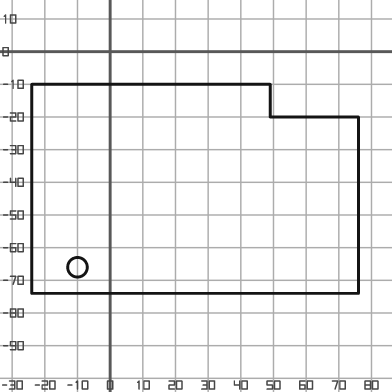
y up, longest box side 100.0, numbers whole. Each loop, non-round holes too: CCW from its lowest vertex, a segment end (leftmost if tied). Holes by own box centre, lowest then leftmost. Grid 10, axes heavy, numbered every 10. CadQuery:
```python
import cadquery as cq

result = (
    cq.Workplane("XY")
    .moveTo(-24.0, -74.0)
    .lineTo(76.0, -74.0)
    .lineTo(76.0, -20.0)
    .lineTo(49.0, -20.0)
    .lineTo(49.0, -10.0)
    .lineTo(-24.0, -10.0)
    .close()
    .moveTo(-10.0, -66.0)
    .circle(3.0)
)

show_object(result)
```